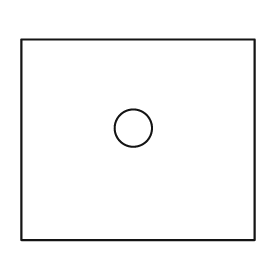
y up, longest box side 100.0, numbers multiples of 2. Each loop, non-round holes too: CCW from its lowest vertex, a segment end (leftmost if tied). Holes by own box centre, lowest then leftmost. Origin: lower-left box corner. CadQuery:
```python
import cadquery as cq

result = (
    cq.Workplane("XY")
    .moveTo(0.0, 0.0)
    .lineTo(100.0, 0.0)
    .lineTo(100.0, 86.0)
    .lineTo(0.0, 86.0)
    .close()
    .moveTo(48.0, 48.0)
    .circle(8.0)
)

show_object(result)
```